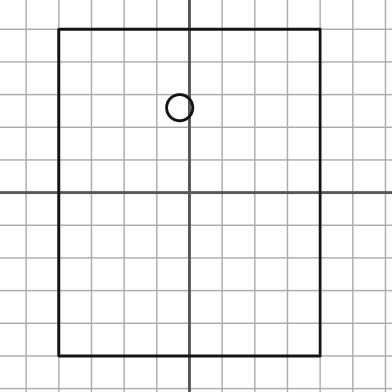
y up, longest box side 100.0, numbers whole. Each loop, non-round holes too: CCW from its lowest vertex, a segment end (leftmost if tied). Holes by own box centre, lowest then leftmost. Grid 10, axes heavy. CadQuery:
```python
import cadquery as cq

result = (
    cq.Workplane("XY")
    .moveTo(-40.0, -50.0)
    .lineTo(40.0, -50.0)
    .lineTo(40.0, 50.0)
    .lineTo(-40.0, 50.0)
    .close()
    .moveTo(-3.0, 26.0)
    .circle(4.0)
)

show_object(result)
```